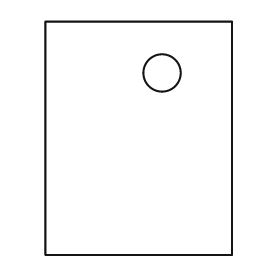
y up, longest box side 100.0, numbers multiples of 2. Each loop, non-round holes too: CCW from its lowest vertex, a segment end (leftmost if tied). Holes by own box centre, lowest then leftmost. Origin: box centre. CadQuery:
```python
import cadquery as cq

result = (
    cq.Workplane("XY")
    .moveTo(-40.0, -50.0)
    .lineTo(40.0, -50.0)
    .lineTo(40.0, 50.0)
    .lineTo(-40.0, 50.0)
    .close()
    .moveTo(10.0, 28.0)
    .circle(8.0)
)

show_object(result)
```